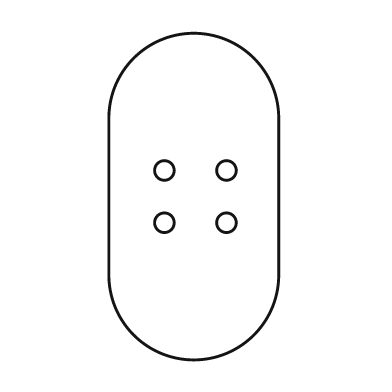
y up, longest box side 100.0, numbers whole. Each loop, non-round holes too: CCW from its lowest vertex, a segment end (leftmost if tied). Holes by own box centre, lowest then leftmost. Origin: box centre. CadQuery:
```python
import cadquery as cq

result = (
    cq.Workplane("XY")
    .moveTo(-26.0, -24.0)
    .threePointArc((0.0, -50.0), (26.0, -24.0))
    .lineTo(26.0, 24.0)
    .threePointArc((0.0, 50.0), (-26.0, 24.0))
    .close()
    .moveTo(-9.0, -8.0)
    .circle(3.0)
    .moveTo(10.0, -8.0)
    .circle(3.0)
    .moveTo(-9.0, 8.0)
    .circle(3.0)
    .moveTo(10.0, 8.0)
    .circle(3.0)
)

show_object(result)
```